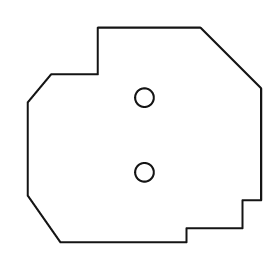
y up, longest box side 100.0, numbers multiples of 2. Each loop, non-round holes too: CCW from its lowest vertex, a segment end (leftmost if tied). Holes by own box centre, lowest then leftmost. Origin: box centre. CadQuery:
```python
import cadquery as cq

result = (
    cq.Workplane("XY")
    .moveTo(-36.0, -46.0)
    .lineTo(18.0, -46.0)
    .lineTo(18.0, -40.0)
    .lineTo(42.0, -40.0)
    .lineTo(42.0, -28.0)
    .lineTo(50.0, -28.0)
    .lineTo(50.0, 20.0)
    .lineTo(24.0, 46.0)
    .lineTo(-20.0, 46.0)
    .lineTo(-20.0, 26.0)
    .lineTo(-40.0, 26.0)
    .lineTo(-50.0, 14.0)
    .lineTo(-50.0, -26.0)
    .close()
    .moveTo(0.0, -16.0)
    .circle(4.0)
    .moveTo(0.0, 16.0)
    .circle(4.0)
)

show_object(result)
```